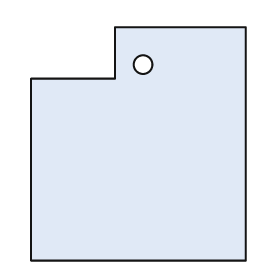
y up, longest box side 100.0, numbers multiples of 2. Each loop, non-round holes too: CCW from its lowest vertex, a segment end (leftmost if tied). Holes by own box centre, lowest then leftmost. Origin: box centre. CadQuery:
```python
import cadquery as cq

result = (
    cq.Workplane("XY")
    .moveTo(-46.0, -50.0)
    .lineTo(46.0, -50.0)
    .lineTo(46.0, 50.0)
    .lineTo(-10.0, 50.0)
    .lineTo(-10.0, 28.0)
    .lineTo(-46.0, 28.0)
    .close()
    .moveTo(2.0, 34.0)
    .circle(4.0)
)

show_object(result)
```